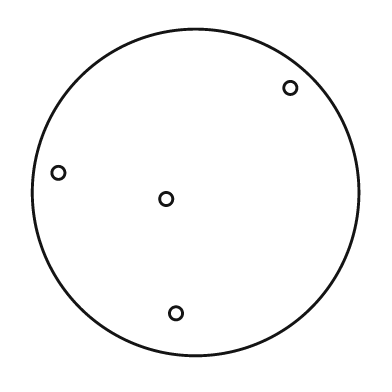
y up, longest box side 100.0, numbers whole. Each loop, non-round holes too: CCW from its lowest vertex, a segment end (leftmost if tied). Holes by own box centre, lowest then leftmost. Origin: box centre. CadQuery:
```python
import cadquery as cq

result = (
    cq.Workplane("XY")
    .moveTo(0.0, 0.0)
    .circle(50.0)
    .moveTo(-6.0, -37.0)
    .circle(2.0)
    .moveTo(-9.0, -2.0)
    .circle(2.0)
    .moveTo(-42.0, 6.0)
    .circle(2.0)
    .moveTo(29.0, 32.0)
    .circle(2.0)
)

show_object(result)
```